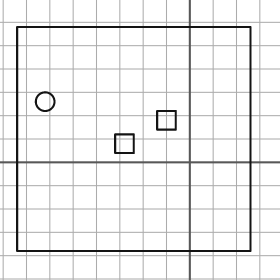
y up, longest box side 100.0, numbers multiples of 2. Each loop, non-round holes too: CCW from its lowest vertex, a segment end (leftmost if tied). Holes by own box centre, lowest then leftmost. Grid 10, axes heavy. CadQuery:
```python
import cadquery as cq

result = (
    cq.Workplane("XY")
    .moveTo(-74.0, -38.0)
    .lineTo(26.0, -38.0)
    .lineTo(26.0, 58.0)
    .lineTo(-74.0, 58.0)
    .close()
    .moveTo(-32.0, 4.0)
    .lineTo(-24.0, 4.0)
    .lineTo(-24.0, 12.0)
    .lineTo(-32.0, 12.0)
    .close()
    .moveTo(-14.0, 14.0)
    .lineTo(-6.0, 14.0)
    .lineTo(-6.0, 22.0)
    .lineTo(-14.0, 22.0)
    .close()
    .moveTo(-62.0, 26.0)
    .circle(4.0)
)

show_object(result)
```